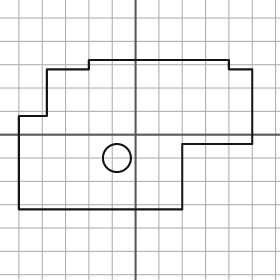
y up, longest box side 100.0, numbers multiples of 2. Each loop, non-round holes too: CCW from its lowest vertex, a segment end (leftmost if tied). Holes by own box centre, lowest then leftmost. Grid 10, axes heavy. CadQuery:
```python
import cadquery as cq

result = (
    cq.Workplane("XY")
    .moveTo(-50.0, -32.0)
    .lineTo(20.0, -32.0)
    .lineTo(20.0, -4.0)
    .lineTo(50.0, -4.0)
    .lineTo(50.0, 28.0)
    .lineTo(40.0, 28.0)
    .lineTo(40.0, 32.0)
    .lineTo(-20.0, 32.0)
    .lineTo(-20.0, 28.0)
    .lineTo(-38.0, 28.0)
    .lineTo(-38.0, 8.0)
    .lineTo(-50.0, 8.0)
    .close()
    .moveTo(-8.0, -10.0)
    .circle(6.0)
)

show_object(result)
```